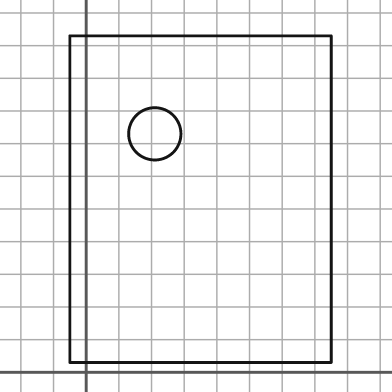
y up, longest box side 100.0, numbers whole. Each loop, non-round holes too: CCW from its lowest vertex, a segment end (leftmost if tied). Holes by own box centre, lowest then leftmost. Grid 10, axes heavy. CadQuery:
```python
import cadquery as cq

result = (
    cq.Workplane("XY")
    .moveTo(-5.0, 3.0)
    .lineTo(75.0, 3.0)
    .lineTo(75.0, 103.0)
    .lineTo(-5.0, 103.0)
    .close()
    .moveTo(21.0, 73.0)
    .circle(8.0)
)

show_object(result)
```